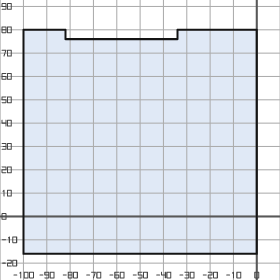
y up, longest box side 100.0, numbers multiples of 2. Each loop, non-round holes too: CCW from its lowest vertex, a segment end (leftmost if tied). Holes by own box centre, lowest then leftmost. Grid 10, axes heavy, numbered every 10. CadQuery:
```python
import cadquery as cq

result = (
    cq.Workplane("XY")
    .moveTo(-100.0, -16.0)
    .lineTo(0.0, -16.0)
    .lineTo(0.0, 80.0)
    .lineTo(-34.0, 80.0)
    .lineTo(-34.0, 76.0)
    .lineTo(-82.0, 76.0)
    .lineTo(-82.0, 80.0)
    .lineTo(-100.0, 80.0)
    .close()
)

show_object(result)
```